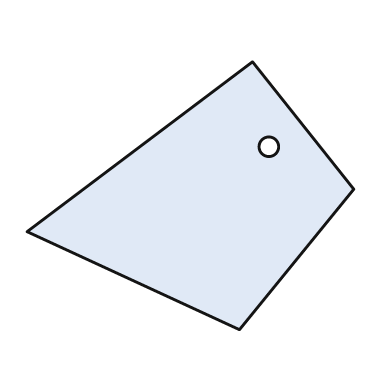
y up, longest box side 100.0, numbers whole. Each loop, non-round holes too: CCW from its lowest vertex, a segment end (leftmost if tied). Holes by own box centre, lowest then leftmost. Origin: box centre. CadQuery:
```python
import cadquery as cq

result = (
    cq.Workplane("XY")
    .moveTo(15.0, -41.0)
    .lineTo(50.0, 2.0)
    .lineTo(19.0, 41.0)
    .lineTo(-50.0, -11.0)
    .close()
    .moveTo(24.0, 15.0)
    .circle(3.0)
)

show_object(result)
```